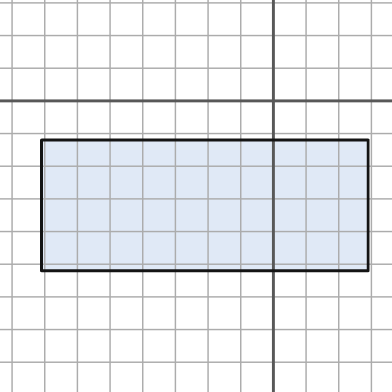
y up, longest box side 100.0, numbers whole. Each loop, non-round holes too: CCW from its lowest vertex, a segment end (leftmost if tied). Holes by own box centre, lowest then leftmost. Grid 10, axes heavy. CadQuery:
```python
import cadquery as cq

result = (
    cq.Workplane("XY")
    .moveTo(-71.0, -52.0)
    .lineTo(29.0, -52.0)
    .lineTo(29.0, -12.0)
    .lineTo(-71.0, -12.0)
    .close()
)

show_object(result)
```